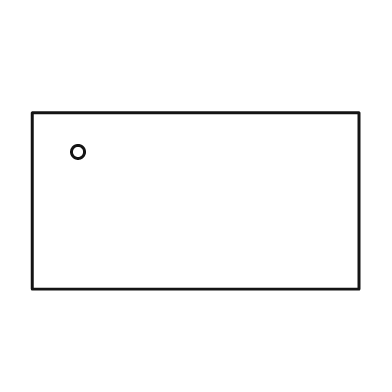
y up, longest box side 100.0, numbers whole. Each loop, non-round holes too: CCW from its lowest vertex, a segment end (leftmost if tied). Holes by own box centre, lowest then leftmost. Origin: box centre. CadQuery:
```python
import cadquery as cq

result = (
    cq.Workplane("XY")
    .moveTo(-50.0, -27.0)
    .lineTo(50.0, -27.0)
    .lineTo(50.0, 27.0)
    .lineTo(-50.0, 27.0)
    .close()
    .moveTo(-36.0, 15.0)
    .circle(2.0)
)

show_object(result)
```